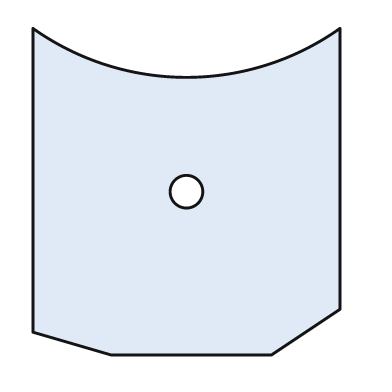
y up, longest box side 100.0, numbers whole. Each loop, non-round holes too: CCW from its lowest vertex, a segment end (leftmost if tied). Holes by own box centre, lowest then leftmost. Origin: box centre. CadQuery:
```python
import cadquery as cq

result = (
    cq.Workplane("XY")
    .moveTo(-23.0, -50.0)
    .lineTo(26.0, -50.0)
    .lineTo(47.0, -36.0)
    .lineTo(47.0, 50.0)
    .threePointArc((0.0, 35.0), (-47.0, 50.0))
    .lineTo(-47.0, -43.0)
    .close()
    .moveTo(0.0, 0.0)
    .circle(5.0)
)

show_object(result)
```